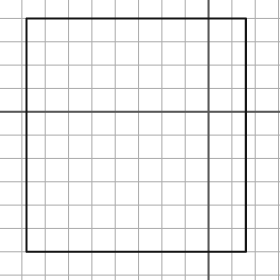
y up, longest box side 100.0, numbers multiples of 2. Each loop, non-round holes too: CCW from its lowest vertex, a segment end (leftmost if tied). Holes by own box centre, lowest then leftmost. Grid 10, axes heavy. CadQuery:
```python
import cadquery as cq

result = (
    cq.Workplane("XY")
    .moveTo(-78.0, -60.0)
    .lineTo(16.0, -60.0)
    .lineTo(16.0, 40.0)
    .lineTo(-78.0, 40.0)
    .close()
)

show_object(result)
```